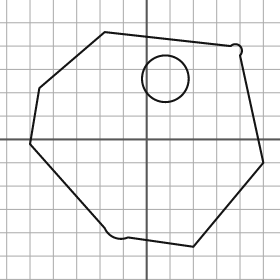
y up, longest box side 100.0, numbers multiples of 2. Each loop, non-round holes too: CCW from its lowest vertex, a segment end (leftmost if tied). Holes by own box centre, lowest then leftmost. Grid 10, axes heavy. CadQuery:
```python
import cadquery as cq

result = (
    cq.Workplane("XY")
    .moveTo(20.0, -46.0)
    .lineTo(50.0, -10.0)
    .lineTo(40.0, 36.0)
    .threePointArc((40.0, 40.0), (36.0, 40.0))
    .lineTo(-18.0, 46.0)
    .lineTo(-46.0, 22.0)
    .lineTo(-50.0, -2.0)
    .lineTo(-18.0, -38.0)
    .threePointArc((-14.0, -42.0), (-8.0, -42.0))
    .close()
    .moveTo(8.0, 26.0)
    .circle(10.0)
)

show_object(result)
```